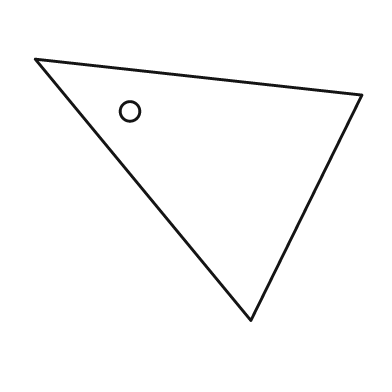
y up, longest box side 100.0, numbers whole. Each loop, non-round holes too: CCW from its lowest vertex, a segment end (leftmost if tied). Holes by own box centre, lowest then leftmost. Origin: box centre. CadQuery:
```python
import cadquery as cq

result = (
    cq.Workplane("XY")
    .moveTo(16.0, -40.0)
    .lineTo(50.0, 29.0)
    .lineTo(-50.0, 40.0)
    .close()
    .moveTo(-21.0, 24.0)
    .circle(3.0)
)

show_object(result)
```